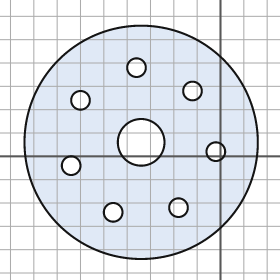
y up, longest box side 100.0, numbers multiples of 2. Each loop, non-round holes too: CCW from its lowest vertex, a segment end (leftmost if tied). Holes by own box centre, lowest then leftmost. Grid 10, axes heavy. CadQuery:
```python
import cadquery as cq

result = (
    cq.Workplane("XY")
    .moveTo(-34.0, 6.0)
    .circle(50.0)
    .moveTo(-46.0, -24.0)
    .circle(4.0)
    .moveTo(-18.0, -22.0)
    .circle(4.0)
    .moveTo(-64.0, -4.0)
    .circle(4.0)
    .moveTo(-2.0, 2.0)
    .circle(4.0)
    .moveTo(-34.0, 6.0)
    .circle(10.0)
    .moveTo(-60.0, 24.0)
    .circle(4.0)
    .moveTo(-12.0, 28.0)
    .circle(4.0)
    .moveTo(-36.0, 38.0)
    .circle(4.0)
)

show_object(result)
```